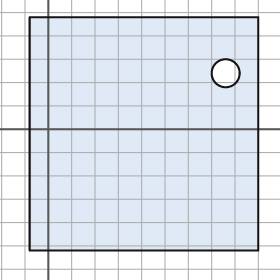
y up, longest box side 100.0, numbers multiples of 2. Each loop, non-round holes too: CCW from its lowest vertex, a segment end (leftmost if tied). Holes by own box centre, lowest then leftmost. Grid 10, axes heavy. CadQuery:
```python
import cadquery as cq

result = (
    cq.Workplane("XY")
    .moveTo(-8.0, -52.0)
    .lineTo(90.0, -52.0)
    .lineTo(90.0, 48.0)
    .lineTo(-8.0, 48.0)
    .close()
    .moveTo(76.0, 24.0)
    .circle(6.0)
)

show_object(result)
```